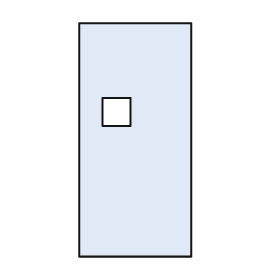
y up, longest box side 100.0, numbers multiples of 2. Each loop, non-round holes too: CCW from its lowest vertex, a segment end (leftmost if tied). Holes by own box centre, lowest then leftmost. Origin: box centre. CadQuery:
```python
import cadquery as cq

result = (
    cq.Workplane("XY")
    .moveTo(-24.0, -50.0)
    .lineTo(24.0, -50.0)
    .lineTo(24.0, 50.0)
    .lineTo(-24.0, 50.0)
    .close()
    .moveTo(-14.0, 6.0)
    .lineTo(-2.0, 6.0)
    .lineTo(-2.0, 18.0)
    .lineTo(-14.0, 18.0)
    .close()
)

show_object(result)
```